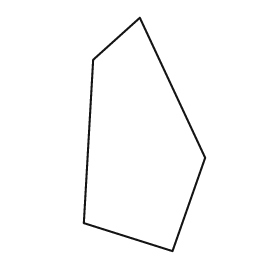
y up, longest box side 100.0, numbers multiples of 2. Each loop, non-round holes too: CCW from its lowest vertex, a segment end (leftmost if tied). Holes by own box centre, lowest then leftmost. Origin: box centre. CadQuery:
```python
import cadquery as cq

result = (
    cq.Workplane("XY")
    .moveTo(12.0, -50.0)
    .lineTo(26.0, -10.0)
    .lineTo(-2.0, 50.0)
    .lineTo(-22.0, 32.0)
    .lineTo(-26.0, -38.0)
    .close()
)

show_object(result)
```